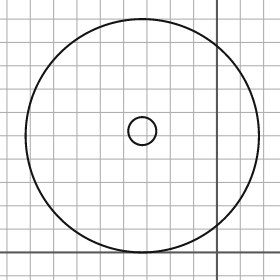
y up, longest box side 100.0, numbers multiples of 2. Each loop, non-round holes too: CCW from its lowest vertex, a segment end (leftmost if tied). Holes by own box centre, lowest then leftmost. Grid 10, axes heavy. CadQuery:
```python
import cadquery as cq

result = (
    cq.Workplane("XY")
    .moveTo(-32.0, 50.0)
    .circle(50.0)
    .moveTo(-32.0, 52.0)
    .circle(6.0)
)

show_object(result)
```